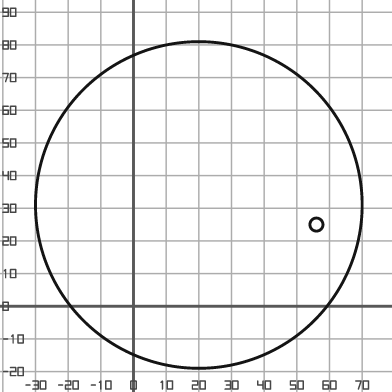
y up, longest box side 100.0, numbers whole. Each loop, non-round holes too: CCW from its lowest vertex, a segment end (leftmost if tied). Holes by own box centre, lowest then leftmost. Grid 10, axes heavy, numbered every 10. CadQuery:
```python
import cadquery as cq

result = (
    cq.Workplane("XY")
    .moveTo(20.0, 31.0)
    .circle(50.0)
    .moveTo(56.0, 25.0)
    .circle(2.0)
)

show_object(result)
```